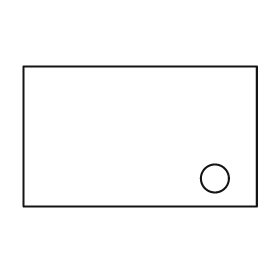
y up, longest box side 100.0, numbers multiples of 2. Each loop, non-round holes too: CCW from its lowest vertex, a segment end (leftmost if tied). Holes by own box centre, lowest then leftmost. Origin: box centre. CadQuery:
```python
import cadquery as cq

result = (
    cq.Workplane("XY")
    .moveTo(-50.0, -30.0)
    .lineTo(50.0, -30.0)
    .lineTo(50.0, 30.0)
    .lineTo(-50.0, 30.0)
    .close()
    .moveTo(32.0, -18.0)
    .circle(6.0)
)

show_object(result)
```